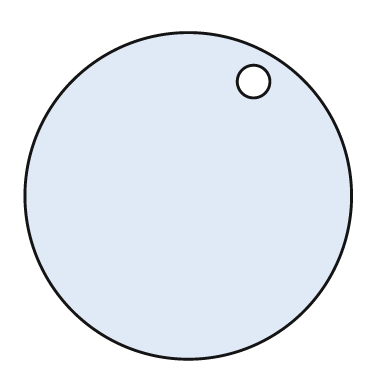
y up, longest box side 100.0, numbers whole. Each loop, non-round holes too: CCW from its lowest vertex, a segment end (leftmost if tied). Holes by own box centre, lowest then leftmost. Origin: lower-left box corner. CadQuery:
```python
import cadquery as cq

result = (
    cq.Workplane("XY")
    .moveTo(50.0, 50.0)
    .circle(50.0)
    .moveTo(70.0, 85.0)
    .circle(5.0)
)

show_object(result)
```